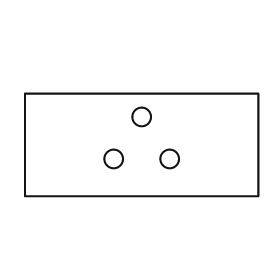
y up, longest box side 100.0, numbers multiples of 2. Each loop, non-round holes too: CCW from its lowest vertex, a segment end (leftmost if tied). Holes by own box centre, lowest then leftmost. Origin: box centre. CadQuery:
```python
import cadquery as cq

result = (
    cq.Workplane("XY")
    .moveTo(-50.0, -22.0)
    .lineTo(50.0, -22.0)
    .lineTo(50.0, 22.0)
    .lineTo(-50.0, 22.0)
    .close()
    .moveTo(-12.0, -6.0)
    .circle(4.0)
    .moveTo(12.0, -6.0)
    .circle(4.0)
    .moveTo(0.0, 12.0)
    .circle(4.0)
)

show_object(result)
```